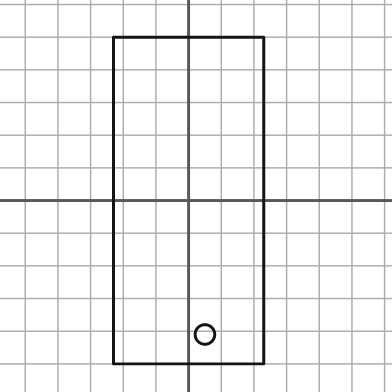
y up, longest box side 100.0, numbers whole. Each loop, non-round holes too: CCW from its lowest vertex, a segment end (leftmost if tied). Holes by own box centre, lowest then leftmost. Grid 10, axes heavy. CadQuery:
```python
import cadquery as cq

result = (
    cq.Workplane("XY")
    .moveTo(-23.0, -50.0)
    .lineTo(23.0, -50.0)
    .lineTo(23.0, 50.0)
    .lineTo(-23.0, 50.0)
    .close()
    .moveTo(5.0, -41.0)
    .circle(3.0)
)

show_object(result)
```